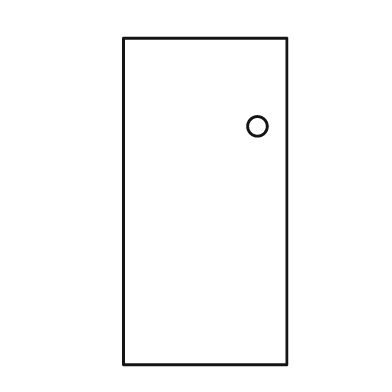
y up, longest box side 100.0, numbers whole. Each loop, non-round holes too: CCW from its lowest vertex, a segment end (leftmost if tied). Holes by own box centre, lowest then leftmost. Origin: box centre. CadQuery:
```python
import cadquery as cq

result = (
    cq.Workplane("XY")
    .moveTo(-25.0, -50.0)
    .lineTo(25.0, -50.0)
    .lineTo(25.0, 50.0)
    .lineTo(-25.0, 50.0)
    .close()
    .moveTo(16.0, 23.0)
    .circle(3.0)
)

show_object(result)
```